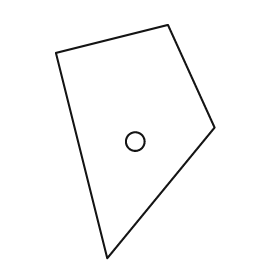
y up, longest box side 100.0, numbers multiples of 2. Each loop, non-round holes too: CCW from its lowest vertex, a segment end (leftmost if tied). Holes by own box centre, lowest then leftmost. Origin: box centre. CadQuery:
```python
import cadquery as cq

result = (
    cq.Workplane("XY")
    .moveTo(-12.0, -50.0)
    .lineTo(34.0, 6.0)
    .lineTo(14.0, 50.0)
    .lineTo(-34.0, 38.0)
    .close()
    .moveTo(0.0, 0.0)
    .circle(4.0)
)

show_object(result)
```